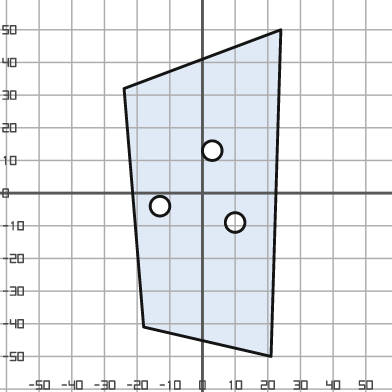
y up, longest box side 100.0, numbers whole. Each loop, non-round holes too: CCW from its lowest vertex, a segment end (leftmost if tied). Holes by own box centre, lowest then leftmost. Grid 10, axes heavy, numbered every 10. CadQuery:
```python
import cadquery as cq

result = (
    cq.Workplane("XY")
    .moveTo(21.0, -50.0)
    .lineTo(24.0, 50.0)
    .lineTo(-24.0, 32.0)
    .lineTo(-18.0, -41.0)
    .close()
    .moveTo(10.0, -9.0)
    .circle(3.0)
    .moveTo(-13.0, -4.0)
    .circle(3.0)
    .moveTo(3.0, 13.0)
    .circle(3.0)
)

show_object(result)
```